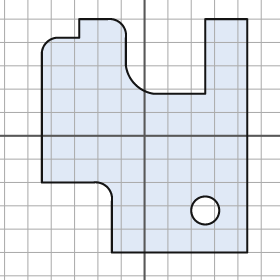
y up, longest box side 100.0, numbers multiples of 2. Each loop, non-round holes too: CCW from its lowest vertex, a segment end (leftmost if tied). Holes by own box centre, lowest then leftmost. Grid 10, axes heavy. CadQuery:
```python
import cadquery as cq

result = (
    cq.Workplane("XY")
    .moveTo(-14.0, -50.0)
    .lineTo(44.0, -50.0)
    .lineTo(44.0, 50.0)
    .lineTo(26.0, 50.0)
    .lineTo(26.0, 18.0)
    .lineTo(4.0, 18.0)
    .threePointArc((-4.0, 22.0), (-8.0, 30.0))
    .lineTo(-8.0, 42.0)
    .threePointArc((-10.0, 48.0), (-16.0, 50.0))
    .lineTo(-28.0, 50.0)
    .lineTo(-28.0, 42.0)
    .lineTo(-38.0, 42.0)
    .threePointArc((-42.0, 40.0), (-44.0, 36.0))
    .lineTo(-44.0, -20.0)
    .lineTo(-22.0, -20.0)
    .threePointArc((-16.0, -22.0), (-14.0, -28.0))
    .close()
    .moveTo(26.0, -32.0)
    .circle(6.0)
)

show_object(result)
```